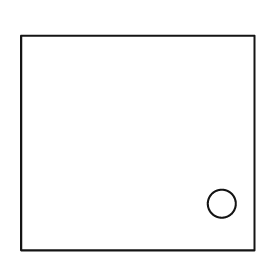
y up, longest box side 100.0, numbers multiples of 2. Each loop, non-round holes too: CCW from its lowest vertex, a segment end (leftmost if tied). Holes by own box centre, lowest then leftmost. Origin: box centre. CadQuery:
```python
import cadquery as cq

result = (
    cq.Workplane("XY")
    .moveTo(-50.0, -46.0)
    .lineTo(50.0, -46.0)
    .lineTo(50.0, 46.0)
    .lineTo(-50.0, 46.0)
    .close()
    .moveTo(36.0, -26.0)
    .circle(6.0)
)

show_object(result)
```